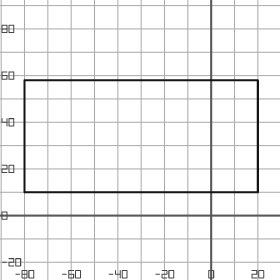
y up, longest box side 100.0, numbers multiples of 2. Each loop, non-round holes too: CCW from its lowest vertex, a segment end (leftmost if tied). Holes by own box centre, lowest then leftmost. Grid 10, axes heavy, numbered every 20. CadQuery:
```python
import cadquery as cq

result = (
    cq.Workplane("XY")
    .moveTo(-80.0, 10.0)
    .lineTo(20.0, 10.0)
    .lineTo(20.0, 58.0)
    .lineTo(-80.0, 58.0)
    .close()
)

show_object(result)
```